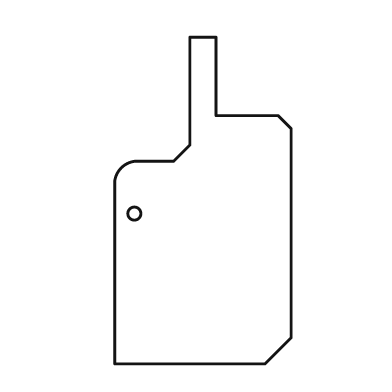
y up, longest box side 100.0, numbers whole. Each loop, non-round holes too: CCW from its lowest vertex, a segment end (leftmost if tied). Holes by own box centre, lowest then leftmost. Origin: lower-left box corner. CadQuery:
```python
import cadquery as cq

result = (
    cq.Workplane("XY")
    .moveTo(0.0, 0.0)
    .lineTo(46.0, 0.0)
    .lineTo(54.0, 8.0)
    .lineTo(54.0, 72.0)
    .lineTo(50.0, 76.0)
    .lineTo(31.0, 76.0)
    .lineTo(31.0, 100.0)
    .lineTo(23.0, 100.0)
    .lineTo(23.0, 67.0)
    .lineTo(18.0, 62.0)
    .lineTo(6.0, 62.0)
    .threePointArc((2.0, 60.0), (0.0, 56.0))
    .close()
    .moveTo(6.0, 46.0)
    .circle(2.0)
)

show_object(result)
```